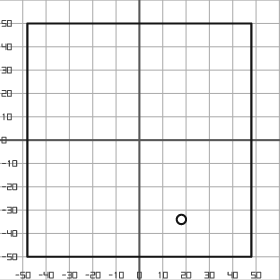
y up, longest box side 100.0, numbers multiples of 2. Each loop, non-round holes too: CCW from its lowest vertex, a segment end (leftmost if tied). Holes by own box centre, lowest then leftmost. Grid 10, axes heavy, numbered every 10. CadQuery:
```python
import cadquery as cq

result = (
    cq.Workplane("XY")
    .moveTo(-48.0, -50.0)
    .lineTo(48.0, -50.0)
    .lineTo(48.0, 50.0)
    .lineTo(-48.0, 50.0)
    .close()
    .moveTo(18.0, -34.0)
    .circle(2.0)
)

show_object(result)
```